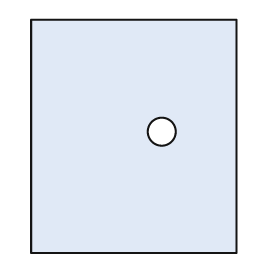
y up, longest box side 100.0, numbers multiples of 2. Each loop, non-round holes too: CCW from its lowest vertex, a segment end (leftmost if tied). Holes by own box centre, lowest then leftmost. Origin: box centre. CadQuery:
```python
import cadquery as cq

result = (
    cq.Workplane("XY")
    .moveTo(-44.0, -50.0)
    .lineTo(44.0, -50.0)
    .lineTo(44.0, 50.0)
    .lineTo(-44.0, 50.0)
    .close()
    .moveTo(12.0, 2.0)
    .circle(6.0)
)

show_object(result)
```